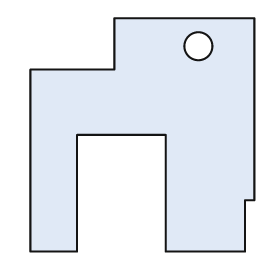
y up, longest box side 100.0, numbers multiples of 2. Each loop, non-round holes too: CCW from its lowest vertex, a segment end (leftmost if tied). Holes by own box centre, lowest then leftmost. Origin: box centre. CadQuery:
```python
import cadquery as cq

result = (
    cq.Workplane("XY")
    .moveTo(-48.0, -50.0)
    .lineTo(-28.0, -50.0)
    .lineTo(-28.0, 0.0)
    .lineTo(10.0, 0.0)
    .lineTo(10.0, -50.0)
    .lineTo(44.0, -50.0)
    .lineTo(44.0, -28.0)
    .lineTo(48.0, -28.0)
    .lineTo(48.0, 50.0)
    .lineTo(-12.0, 50.0)
    .lineTo(-12.0, 28.0)
    .lineTo(-48.0, 28.0)
    .close()
    .moveTo(24.0, 38.0)
    .circle(6.0)
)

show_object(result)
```